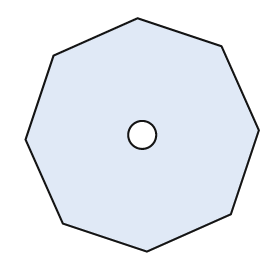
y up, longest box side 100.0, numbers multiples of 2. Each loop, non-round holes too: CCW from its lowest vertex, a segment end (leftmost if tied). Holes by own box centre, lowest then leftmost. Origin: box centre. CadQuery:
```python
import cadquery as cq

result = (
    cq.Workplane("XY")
    .moveTo(2.0, -50.0)
    .lineTo(38.0, -34.0)
    .lineTo(50.0, 2.0)
    .lineTo(34.0, 38.0)
    .lineTo(-2.0, 50.0)
    .lineTo(-38.0, 34.0)
    .lineTo(-50.0, -2.0)
    .lineTo(-34.0, -38.0)
    .close()
    .moveTo(0.0, 0.0)
    .circle(6.0)
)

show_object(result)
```